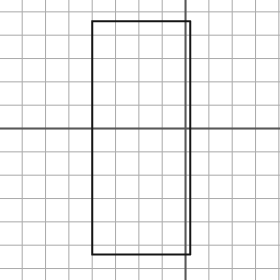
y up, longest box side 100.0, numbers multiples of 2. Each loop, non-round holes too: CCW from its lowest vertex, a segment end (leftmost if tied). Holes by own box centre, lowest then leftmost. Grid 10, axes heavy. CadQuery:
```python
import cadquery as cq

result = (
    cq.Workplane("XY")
    .moveTo(-40.0, -54.0)
    .lineTo(2.0, -54.0)
    .lineTo(2.0, 46.0)
    .lineTo(-40.0, 46.0)
    .close()
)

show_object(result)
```